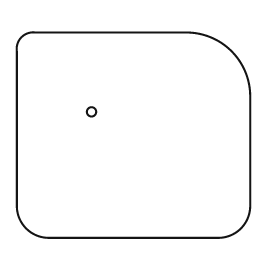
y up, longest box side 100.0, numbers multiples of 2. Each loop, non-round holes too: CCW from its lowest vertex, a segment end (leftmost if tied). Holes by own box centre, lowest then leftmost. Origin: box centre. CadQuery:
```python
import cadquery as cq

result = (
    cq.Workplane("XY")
    .moveTo(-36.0, -44.0)
    .lineTo(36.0, -44.0)
    .threePointArc((46.0, -40.0), (50.0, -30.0))
    .lineTo(50.0, 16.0)
    .threePointArc((42.0, 36.0), (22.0, 44.0))
    .lineTo(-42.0, 44.0)
    .threePointArc((-48.0, 42.0), (-50.0, 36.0))
    .lineTo(-50.0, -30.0)
    .threePointArc((-46.0, -40.0), (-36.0, -44.0))
    .close()
    .moveTo(-18.0, 10.0)
    .circle(2.0)
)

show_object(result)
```